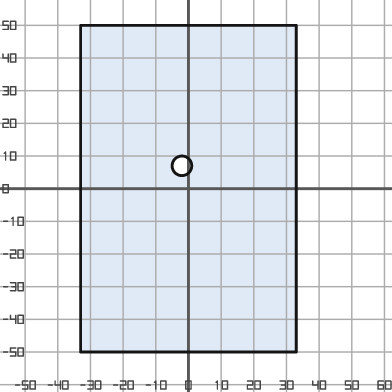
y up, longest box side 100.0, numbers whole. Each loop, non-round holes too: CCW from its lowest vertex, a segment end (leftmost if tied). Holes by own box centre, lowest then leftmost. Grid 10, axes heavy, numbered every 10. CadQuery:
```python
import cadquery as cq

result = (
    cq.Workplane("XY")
    .moveTo(-33.0, -50.0)
    .lineTo(33.0, -50.0)
    .lineTo(33.0, 50.0)
    .lineTo(-33.0, 50.0)
    .close()
    .moveTo(-2.0, 7.0)
    .circle(3.0)
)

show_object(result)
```